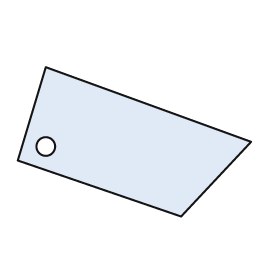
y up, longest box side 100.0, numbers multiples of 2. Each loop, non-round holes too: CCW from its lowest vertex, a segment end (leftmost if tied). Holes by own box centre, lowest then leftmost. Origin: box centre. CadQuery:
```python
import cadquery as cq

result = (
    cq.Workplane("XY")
    .moveTo(20.0, -32.0)
    .lineTo(50.0, 0.0)
    .lineTo(-38.0, 32.0)
    .lineTo(-50.0, -8.0)
    .close()
    .moveTo(-38.0, -2.0)
    .circle(4.0)
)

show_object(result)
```